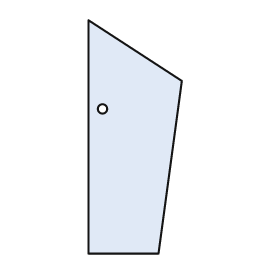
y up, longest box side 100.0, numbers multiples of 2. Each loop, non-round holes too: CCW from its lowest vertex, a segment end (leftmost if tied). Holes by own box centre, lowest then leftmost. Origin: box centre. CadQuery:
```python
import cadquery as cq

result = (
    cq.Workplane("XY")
    .moveTo(-20.0, -50.0)
    .lineTo(10.0, -50.0)
    .lineTo(20.0, 24.0)
    .lineTo(-20.0, 50.0)
    .close()
    .moveTo(-14.0, 12.0)
    .circle(2.0)
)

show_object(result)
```